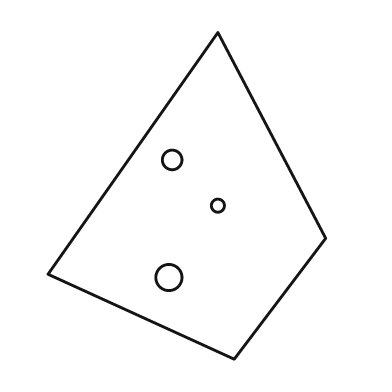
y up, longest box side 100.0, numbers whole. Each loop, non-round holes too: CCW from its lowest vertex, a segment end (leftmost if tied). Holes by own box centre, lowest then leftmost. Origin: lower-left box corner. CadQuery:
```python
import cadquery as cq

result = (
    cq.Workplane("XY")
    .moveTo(57.0, 0.0)
    .lineTo(85.0, 37.0)
    .lineTo(52.0, 100.0)
    .lineTo(0.0, 26.0)
    .close()
    .moveTo(37.0, 25.0)
    .circle(4.0)
    .moveTo(52.0, 47.0)
    .circle(2.0)
    .moveTo(38.0, 61.0)
    .circle(3.0)
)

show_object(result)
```